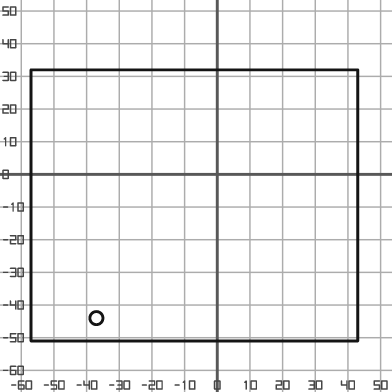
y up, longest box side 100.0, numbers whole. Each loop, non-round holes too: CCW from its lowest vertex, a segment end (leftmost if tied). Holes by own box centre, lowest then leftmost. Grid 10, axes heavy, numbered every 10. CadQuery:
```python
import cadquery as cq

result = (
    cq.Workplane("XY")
    .moveTo(-57.0, -51.0)
    .lineTo(43.0, -51.0)
    .lineTo(43.0, 32.0)
    .lineTo(-57.0, 32.0)
    .close()
    .moveTo(-37.0, -44.0)
    .circle(2.0)
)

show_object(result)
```